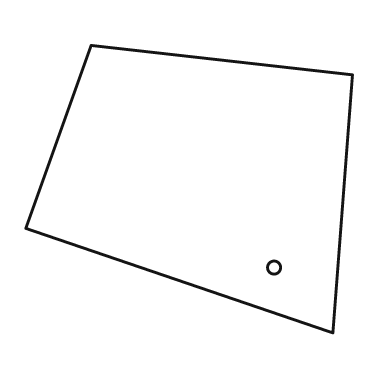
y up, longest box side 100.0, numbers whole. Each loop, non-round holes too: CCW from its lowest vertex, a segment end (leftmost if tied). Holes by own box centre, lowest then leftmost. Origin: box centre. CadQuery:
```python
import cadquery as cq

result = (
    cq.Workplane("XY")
    .moveTo(44.0, -44.0)
    .lineTo(50.0, 35.0)
    .lineTo(-30.0, 44.0)
    .lineTo(-50.0, -12.0)
    .close()
    .moveTo(26.0, -24.0)
    .circle(2.0)
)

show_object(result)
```